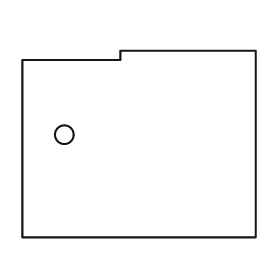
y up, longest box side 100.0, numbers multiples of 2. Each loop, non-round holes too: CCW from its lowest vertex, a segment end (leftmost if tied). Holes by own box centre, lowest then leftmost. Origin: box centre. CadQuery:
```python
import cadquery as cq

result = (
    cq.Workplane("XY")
    .moveTo(-50.0, -40.0)
    .lineTo(50.0, -40.0)
    .lineTo(50.0, 40.0)
    .lineTo(-8.0, 40.0)
    .lineTo(-8.0, 36.0)
    .lineTo(-50.0, 36.0)
    .close()
    .moveTo(-32.0, 4.0)
    .circle(4.0)
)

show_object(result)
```